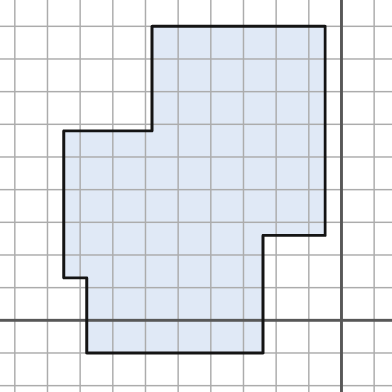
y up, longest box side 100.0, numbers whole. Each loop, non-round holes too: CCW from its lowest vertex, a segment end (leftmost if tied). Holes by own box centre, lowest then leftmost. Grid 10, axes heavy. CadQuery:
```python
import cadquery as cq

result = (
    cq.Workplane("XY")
    .moveTo(-78.0, -10.0)
    .lineTo(-24.0, -10.0)
    .lineTo(-24.0, 26.0)
    .lineTo(-5.0, 26.0)
    .lineTo(-5.0, 90.0)
    .lineTo(-58.0, 90.0)
    .lineTo(-58.0, 58.0)
    .lineTo(-85.0, 58.0)
    .lineTo(-85.0, 13.0)
    .lineTo(-78.0, 13.0)
    .close()
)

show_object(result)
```